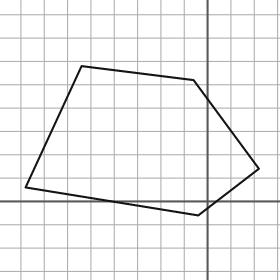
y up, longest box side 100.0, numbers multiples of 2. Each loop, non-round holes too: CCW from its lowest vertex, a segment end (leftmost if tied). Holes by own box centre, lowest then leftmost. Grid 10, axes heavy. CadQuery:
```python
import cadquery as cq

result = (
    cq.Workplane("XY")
    .moveTo(-4.0, -6.0)
    .lineTo(22.0, 14.0)
    .lineTo(-6.0, 52.0)
    .lineTo(-54.0, 58.0)
    .lineTo(-78.0, 6.0)
    .close()
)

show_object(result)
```